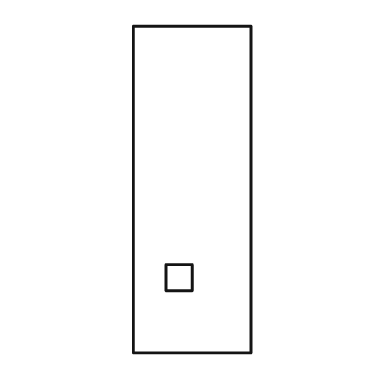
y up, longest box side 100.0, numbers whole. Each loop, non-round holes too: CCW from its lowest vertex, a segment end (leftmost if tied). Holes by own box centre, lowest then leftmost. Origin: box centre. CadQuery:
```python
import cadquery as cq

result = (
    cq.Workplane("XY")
    .moveTo(-18.0, -50.0)
    .lineTo(18.0, -50.0)
    .lineTo(18.0, 50.0)
    .lineTo(-18.0, 50.0)
    .close()
    .moveTo(-8.0, -31.0)
    .lineTo(0.0, -31.0)
    .lineTo(0.0, -23.0)
    .lineTo(-8.0, -23.0)
    .close()
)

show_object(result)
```